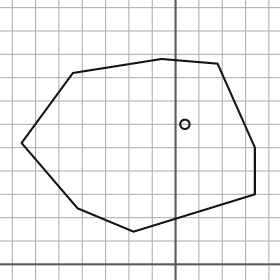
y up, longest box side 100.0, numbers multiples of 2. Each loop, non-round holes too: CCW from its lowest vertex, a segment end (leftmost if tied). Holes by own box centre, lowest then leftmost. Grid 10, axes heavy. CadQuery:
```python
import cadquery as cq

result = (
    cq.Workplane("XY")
    .moveTo(-18.0, 14.0)
    .lineTo(34.0, 30.0)
    .lineTo(34.0, 50.0)
    .lineTo(18.0, 86.0)
    .lineTo(-6.0, 88.0)
    .lineTo(-44.0, 82.0)
    .lineTo(-66.0, 52.0)
    .lineTo(-42.0, 24.0)
    .close()
    .moveTo(4.0, 60.0)
    .circle(2.0)
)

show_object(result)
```